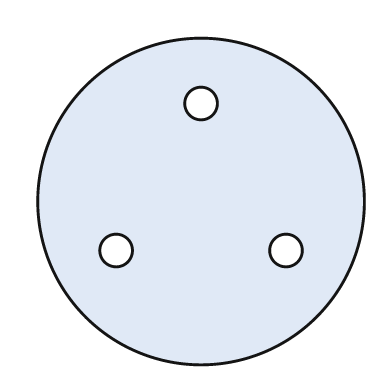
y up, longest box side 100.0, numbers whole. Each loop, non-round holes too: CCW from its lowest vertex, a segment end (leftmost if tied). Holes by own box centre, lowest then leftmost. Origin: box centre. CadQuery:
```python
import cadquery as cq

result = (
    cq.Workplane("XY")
    .moveTo(0.0, 0.0)
    .circle(50.0)
    .moveTo(-26.0, -15.0)
    .circle(5.0)
    .moveTo(26.0, -15.0)
    .circle(5.0)
    .moveTo(0.0, 30.0)
    .circle(5.0)
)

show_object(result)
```